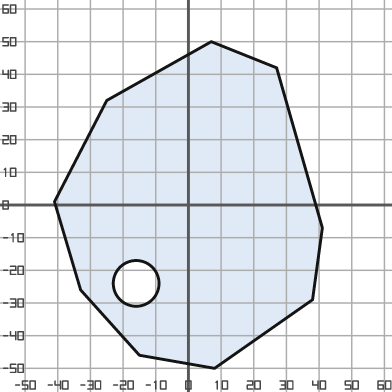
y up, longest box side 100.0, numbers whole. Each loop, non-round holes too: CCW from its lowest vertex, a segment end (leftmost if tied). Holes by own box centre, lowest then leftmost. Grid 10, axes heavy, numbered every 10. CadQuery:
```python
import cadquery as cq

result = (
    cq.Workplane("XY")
    .moveTo(8.0, -50.0)
    .lineTo(38.0, -29.0)
    .lineTo(41.0, -7.0)
    .lineTo(27.0, 42.0)
    .lineTo(7.0, 50.0)
    .lineTo(-25.0, 32.0)
    .lineTo(-41.0, 1.0)
    .lineTo(-33.0, -26.0)
    .lineTo(-15.0, -46.0)
    .close()
    .moveTo(-16.0, -24.0)
    .circle(7.0)
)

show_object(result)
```